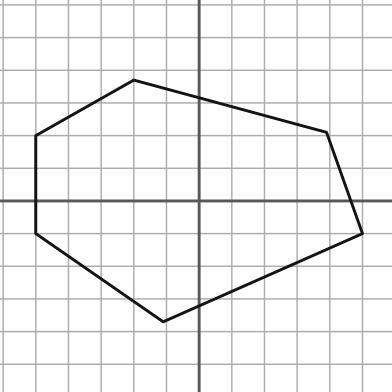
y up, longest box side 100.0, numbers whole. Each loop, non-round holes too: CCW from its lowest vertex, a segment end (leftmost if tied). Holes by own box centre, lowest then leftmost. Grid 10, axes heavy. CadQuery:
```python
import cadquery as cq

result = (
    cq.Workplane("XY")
    .moveTo(-11.0, -37.0)
    .lineTo(50.0, -10.0)
    .lineTo(39.0, 21.0)
    .lineTo(-20.0, 37.0)
    .lineTo(-50.0, 20.0)
    .lineTo(-50.0, -10.0)
    .close()
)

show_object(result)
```